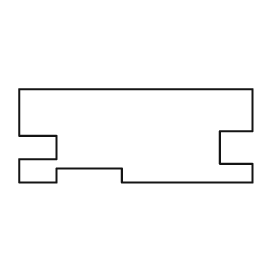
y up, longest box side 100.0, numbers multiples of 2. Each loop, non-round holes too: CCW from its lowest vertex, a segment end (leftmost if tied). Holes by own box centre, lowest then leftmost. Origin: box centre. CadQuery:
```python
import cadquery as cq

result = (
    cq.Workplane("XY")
    .moveTo(-50.0, -20.0)
    .lineTo(-34.0, -20.0)
    .lineTo(-34.0, -14.0)
    .lineTo(-6.0, -14.0)
    .lineTo(-6.0, -20.0)
    .lineTo(50.0, -20.0)
    .lineTo(50.0, -12.0)
    .lineTo(36.0, -12.0)
    .lineTo(36.0, 2.0)
    .lineTo(50.0, 2.0)
    .lineTo(50.0, 20.0)
    .lineTo(-50.0, 20.0)
    .lineTo(-50.0, 0.0)
    .lineTo(-34.0, 0.0)
    .lineTo(-34.0, -10.0)
    .lineTo(-50.0, -10.0)
    .close()
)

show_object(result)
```